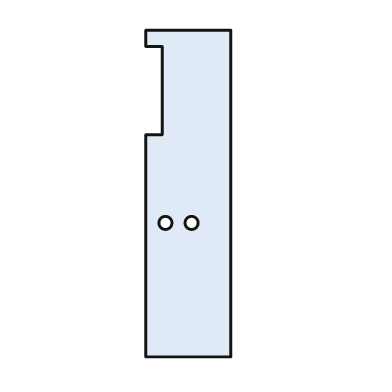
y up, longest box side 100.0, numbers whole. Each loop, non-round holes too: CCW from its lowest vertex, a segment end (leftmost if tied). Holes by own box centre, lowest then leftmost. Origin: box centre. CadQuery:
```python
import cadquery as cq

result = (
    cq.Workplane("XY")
    .moveTo(-13.0, -50.0)
    .lineTo(13.0, -50.0)
    .lineTo(13.0, 50.0)
    .lineTo(-13.0, 50.0)
    .lineTo(-13.0, 45.0)
    .lineTo(-8.0, 45.0)
    .lineTo(-8.0, 18.0)
    .lineTo(-13.0, 18.0)
    .close()
    .moveTo(-7.0, -9.0)
    .circle(2.0)
    .moveTo(1.0, -9.0)
    .circle(2.0)
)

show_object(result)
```